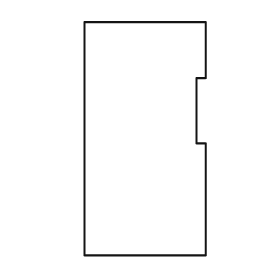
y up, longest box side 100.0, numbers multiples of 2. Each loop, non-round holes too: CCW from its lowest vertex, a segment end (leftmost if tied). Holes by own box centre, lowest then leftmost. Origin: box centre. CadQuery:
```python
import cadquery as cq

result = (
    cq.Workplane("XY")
    .moveTo(-26.0, -50.0)
    .lineTo(26.0, -50.0)
    .lineTo(26.0, -2.0)
    .lineTo(22.0, -2.0)
    .lineTo(22.0, 26.0)
    .lineTo(26.0, 26.0)
    .lineTo(26.0, 50.0)
    .lineTo(-26.0, 50.0)
    .close()
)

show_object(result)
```